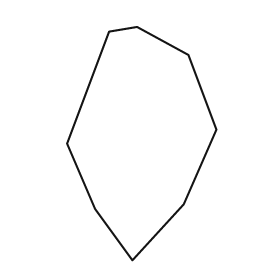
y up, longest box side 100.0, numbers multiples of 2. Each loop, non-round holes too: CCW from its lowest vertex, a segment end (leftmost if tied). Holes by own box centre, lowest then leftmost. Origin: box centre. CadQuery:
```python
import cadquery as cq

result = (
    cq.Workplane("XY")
    .moveTo(-4.0, -50.0)
    .lineTo(18.0, -26.0)
    .lineTo(32.0, 6.0)
    .lineTo(20.0, 38.0)
    .lineTo(-2.0, 50.0)
    .lineTo(-14.0, 48.0)
    .lineTo(-32.0, 0.0)
    .lineTo(-20.0, -28.0)
    .close()
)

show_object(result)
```